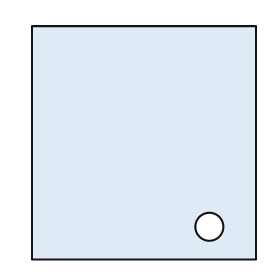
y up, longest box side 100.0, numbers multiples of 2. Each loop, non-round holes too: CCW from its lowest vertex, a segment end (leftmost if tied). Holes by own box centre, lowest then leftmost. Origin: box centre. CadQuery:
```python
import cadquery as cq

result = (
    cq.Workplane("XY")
    .moveTo(-48.0, -50.0)
    .lineTo(48.0, -50.0)
    .lineTo(48.0, 50.0)
    .lineTo(-48.0, 50.0)
    .close()
    .moveTo(28.0, -36.0)
    .circle(6.0)
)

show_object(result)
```